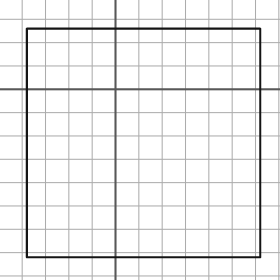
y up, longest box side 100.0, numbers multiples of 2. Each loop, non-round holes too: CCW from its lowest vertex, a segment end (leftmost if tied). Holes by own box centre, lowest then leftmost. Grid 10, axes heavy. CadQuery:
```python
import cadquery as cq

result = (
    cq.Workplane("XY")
    .moveTo(-38.0, -72.0)
    .lineTo(62.0, -72.0)
    .lineTo(62.0, 26.0)
    .lineTo(-38.0, 26.0)
    .close()
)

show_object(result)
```